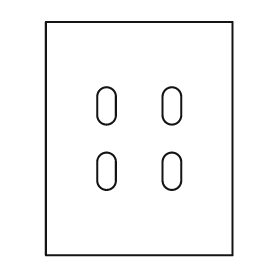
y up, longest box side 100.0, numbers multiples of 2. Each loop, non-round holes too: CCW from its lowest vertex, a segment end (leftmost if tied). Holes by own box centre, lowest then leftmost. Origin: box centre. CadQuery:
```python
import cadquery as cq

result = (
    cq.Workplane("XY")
    .moveTo(-40.0, -50.0)
    .lineTo(40.0, -50.0)
    .lineTo(40.0, 50.0)
    .lineTo(-40.0, 50.0)
    .close()
    .moveTo(-18.0, -18.0)
    .threePointArc((-14.0, -22.0), (-10.0, -18.0))
    .lineTo(-10.0, -10.0)
    .threePointArc((-14.0, -6.0), (-18.0, -10.0))
    .close()
    .moveTo(10.0, -18.0)
    .threePointArc((14.0, -22.0), (18.0, -18.0))
    .lineTo(18.0, -10.0)
    .threePointArc((14.0, -6.0), (10.0, -10.0))
    .close()
    .moveTo(-18.0, 10.0)
    .threePointArc((-14.0, 6.0), (-10.0, 10.0))
    .lineTo(-10.0, 18.0)
    .threePointArc((-14.0, 22.0), (-18.0, 18.0))
    .close()
    .moveTo(10.0, 10.0)
    .threePointArc((14.0, 6.0), (18.0, 10.0))
    .lineTo(18.0, 18.0)
    .threePointArc((14.0, 22.0), (10.0, 18.0))
    .close()
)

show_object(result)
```